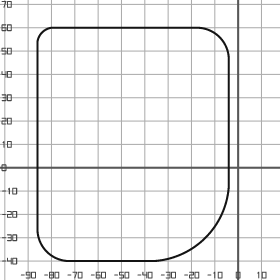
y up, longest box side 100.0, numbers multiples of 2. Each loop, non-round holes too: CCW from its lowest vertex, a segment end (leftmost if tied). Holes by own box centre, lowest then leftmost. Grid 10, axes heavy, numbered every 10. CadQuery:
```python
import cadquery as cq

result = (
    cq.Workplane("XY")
    .moveTo(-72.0, -40.0)
    .lineTo(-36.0, -40.0)
    .threePointArc((-14.0, -30.0), (-4.0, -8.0))
    .lineTo(-4.0, 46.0)
    .threePointArc((-8.0, 56.0), (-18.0, 60.0))
    .lineTo(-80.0, 60.0)
    .threePointArc((-84.0, 58.0), (-86.0, 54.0))
    .lineTo(-86.0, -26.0)
    .threePointArc((-82.0, -36.0), (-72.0, -40.0))
    .close()
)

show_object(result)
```